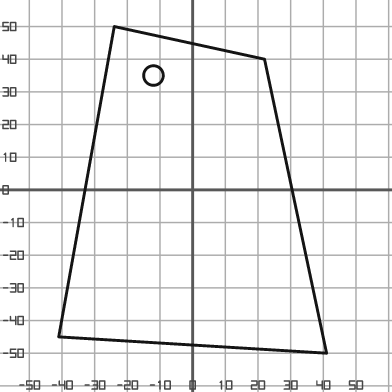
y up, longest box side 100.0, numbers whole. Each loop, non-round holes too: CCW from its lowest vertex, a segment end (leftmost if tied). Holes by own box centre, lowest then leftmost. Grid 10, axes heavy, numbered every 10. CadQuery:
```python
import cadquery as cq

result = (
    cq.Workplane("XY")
    .moveTo(41.0, -50.0)
    .lineTo(22.0, 40.0)
    .lineTo(-24.0, 50.0)
    .lineTo(-41.0, -45.0)
    .close()
    .moveTo(-12.0, 35.0)
    .circle(3.0)
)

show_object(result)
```